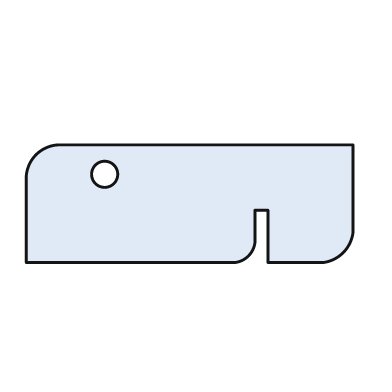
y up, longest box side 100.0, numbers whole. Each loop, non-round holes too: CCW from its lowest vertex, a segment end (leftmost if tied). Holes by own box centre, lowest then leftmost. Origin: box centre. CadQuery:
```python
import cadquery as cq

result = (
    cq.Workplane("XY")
    .moveTo(-50.0, -18.0)
    .lineTo(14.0, -18.0)
    .threePointArc((18.0, -16.0), (20.0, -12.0))
    .lineTo(20.0, -2.0)
    .lineTo(24.0, -2.0)
    .lineTo(24.0, -18.0)
    .lineTo(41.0, -18.0)
    .threePointArc((47.0, -15.0), (50.0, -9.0))
    .lineTo(50.0, 18.0)
    .lineTo(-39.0, 18.0)
    .threePointArc((-47.0, 15.0), (-50.0, 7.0))
    .close()
    .moveTo(-26.0, 9.0)
    .circle(4.0)
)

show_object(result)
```